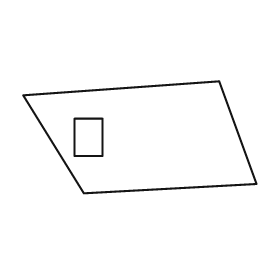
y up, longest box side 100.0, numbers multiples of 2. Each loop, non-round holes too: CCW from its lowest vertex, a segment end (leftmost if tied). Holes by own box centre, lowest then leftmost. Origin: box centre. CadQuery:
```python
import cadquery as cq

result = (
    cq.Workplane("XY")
    .moveTo(-24.0, -24.0)
    .lineTo(50.0, -20.0)
    .lineTo(34.0, 24.0)
    .lineTo(-50.0, 18.0)
    .close()
    .moveTo(-28.0, -8.0)
    .lineTo(-16.0, -8.0)
    .lineTo(-16.0, 8.0)
    .lineTo(-28.0, 8.0)
    .close()
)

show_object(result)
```